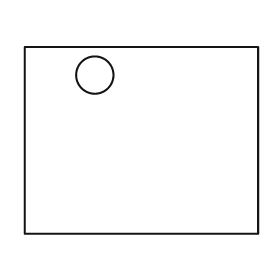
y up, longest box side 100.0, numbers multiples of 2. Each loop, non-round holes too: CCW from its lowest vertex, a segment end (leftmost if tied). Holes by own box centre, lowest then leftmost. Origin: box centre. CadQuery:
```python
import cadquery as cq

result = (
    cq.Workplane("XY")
    .moveTo(-50.0, -40.0)
    .lineTo(50.0, -40.0)
    .lineTo(50.0, 40.0)
    .lineTo(-50.0, 40.0)
    .close()
    .moveTo(-20.0, 28.0)
    .circle(8.0)
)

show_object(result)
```